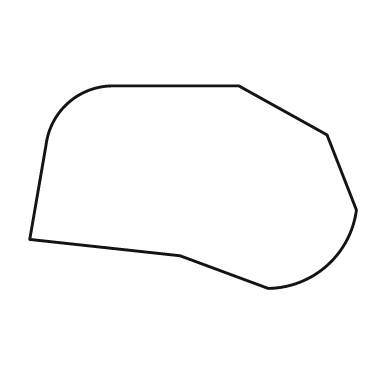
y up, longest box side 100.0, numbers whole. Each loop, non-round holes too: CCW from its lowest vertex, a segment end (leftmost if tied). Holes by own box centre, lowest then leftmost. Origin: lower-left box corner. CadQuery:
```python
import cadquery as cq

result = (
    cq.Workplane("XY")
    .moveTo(73.0, 0.0)
    .threePointArc((91.0, 7.0), (100.0, 24.0))
    .lineTo(91.0, 47.0)
    .lineTo(64.0, 62.0)
    .lineTo(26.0, 62.0)
    .threePointArc((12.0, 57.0), (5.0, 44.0))
    .lineTo(0.0, 15.0)
    .lineTo(46.0, 10.0)
    .close()
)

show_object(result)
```